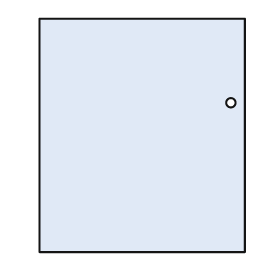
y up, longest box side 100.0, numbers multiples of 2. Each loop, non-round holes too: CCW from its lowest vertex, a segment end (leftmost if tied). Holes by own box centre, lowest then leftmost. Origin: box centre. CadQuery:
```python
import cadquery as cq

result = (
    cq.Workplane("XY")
    .moveTo(-44.0, -50.0)
    .lineTo(44.0, -50.0)
    .lineTo(44.0, 50.0)
    .lineTo(-44.0, 50.0)
    .close()
    .moveTo(38.0, 14.0)
    .circle(2.0)
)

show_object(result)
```